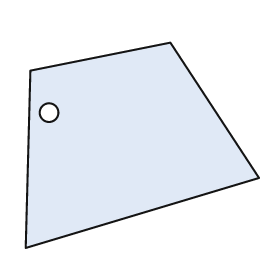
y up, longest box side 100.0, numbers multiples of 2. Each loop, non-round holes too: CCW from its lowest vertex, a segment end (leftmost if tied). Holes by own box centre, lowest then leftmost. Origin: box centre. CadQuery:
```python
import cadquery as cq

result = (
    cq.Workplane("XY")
    .moveTo(-50.0, -44.0)
    .lineTo(50.0, -14.0)
    .lineTo(12.0, 44.0)
    .lineTo(-48.0, 32.0)
    .close()
    .moveTo(-40.0, 14.0)
    .circle(4.0)
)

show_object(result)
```